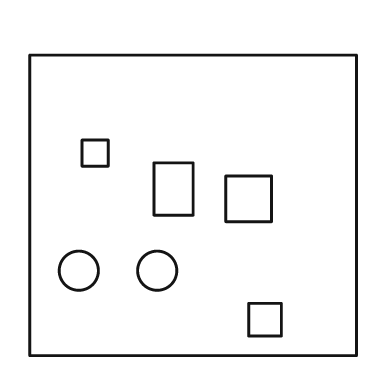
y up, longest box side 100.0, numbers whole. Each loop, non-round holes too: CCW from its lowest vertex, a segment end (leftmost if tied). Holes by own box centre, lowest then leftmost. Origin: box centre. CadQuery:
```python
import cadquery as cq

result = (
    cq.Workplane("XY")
    .moveTo(-50.0, -46.0)
    .lineTo(50.0, -46.0)
    .lineTo(50.0, 46.0)
    .lineTo(-50.0, 46.0)
    .close()
    .moveTo(17.0, -40.0)
    .lineTo(27.0, -40.0)
    .lineTo(27.0, -30.0)
    .lineTo(17.0, -30.0)
    .close()
    .moveTo(-35.0, -20.0)
    .circle(6.0)
    .moveTo(-11.0, -20.0)
    .circle(6.0)
    .moveTo(10.0, -5.0)
    .lineTo(24.0, -5.0)
    .lineTo(24.0, 9.0)
    .lineTo(10.0, 9.0)
    .close()
    .moveTo(-12.0, -3.0)
    .lineTo(0.0, -3.0)
    .lineTo(0.0, 13.0)
    .lineTo(-12.0, 13.0)
    .close()
    .moveTo(-34.0, 12.0)
    .lineTo(-26.0, 12.0)
    .lineTo(-26.0, 20.0)
    .lineTo(-34.0, 20.0)
    .close()
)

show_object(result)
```